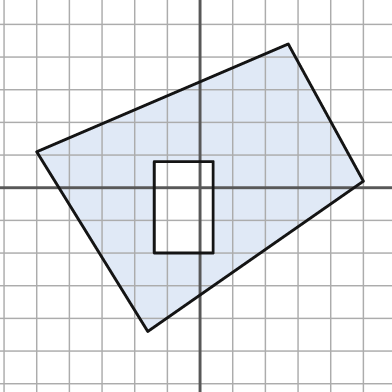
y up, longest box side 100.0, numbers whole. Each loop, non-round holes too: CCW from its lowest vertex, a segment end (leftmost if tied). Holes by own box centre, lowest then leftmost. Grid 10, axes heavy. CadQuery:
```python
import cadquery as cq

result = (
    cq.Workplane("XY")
    .moveTo(-16.0, -44.0)
    .lineTo(50.0, 2.0)
    .lineTo(27.0, 44.0)
    .lineTo(-50.0, 11.0)
    .close()
    .moveTo(-14.0, -20.0)
    .lineTo(4.0, -20.0)
    .lineTo(4.0, 8.0)
    .lineTo(-14.0, 8.0)
    .close()
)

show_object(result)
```